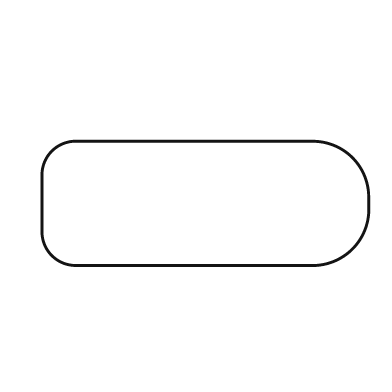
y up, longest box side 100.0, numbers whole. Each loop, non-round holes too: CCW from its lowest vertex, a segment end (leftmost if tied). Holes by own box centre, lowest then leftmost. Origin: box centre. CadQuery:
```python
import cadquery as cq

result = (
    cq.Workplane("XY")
    .moveTo(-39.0, -19.0)
    .lineTo(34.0, -19.0)
    .threePointArc((45.0, -14.0), (50.0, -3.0))
    .lineTo(50.0, 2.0)
    .threePointArc((45.0, 14.0), (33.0, 19.0))
    .lineTo(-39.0, 19.0)
    .threePointArc((-47.0, 16.0), (-50.0, 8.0))
    .lineTo(-50.0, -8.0)
    .threePointArc((-47.0, -16.0), (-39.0, -19.0))
    .close()
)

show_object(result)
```